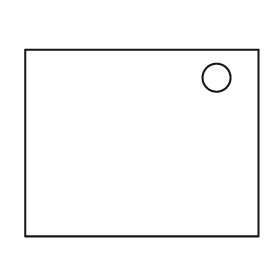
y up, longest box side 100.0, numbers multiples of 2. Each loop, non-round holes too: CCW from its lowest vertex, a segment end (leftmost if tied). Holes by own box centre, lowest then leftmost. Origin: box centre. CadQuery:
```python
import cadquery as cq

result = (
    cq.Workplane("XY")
    .moveTo(-50.0, -40.0)
    .lineTo(50.0, -40.0)
    .lineTo(50.0, 40.0)
    .lineTo(-50.0, 40.0)
    .close()
    .moveTo(32.0, 28.0)
    .circle(6.0)
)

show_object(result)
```